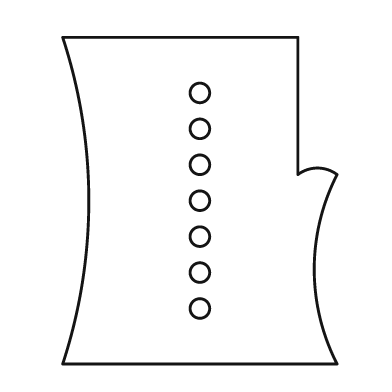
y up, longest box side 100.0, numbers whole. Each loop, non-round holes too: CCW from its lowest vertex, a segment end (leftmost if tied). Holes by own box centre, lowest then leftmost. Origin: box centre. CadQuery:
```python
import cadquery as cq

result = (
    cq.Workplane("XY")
    .moveTo(-42.0, -50.0)
    .lineTo(42.0, -50.0)
    .threePointArc((35.0, -21.0), (42.0, 8.0))
    .threePointArc((36.0, 10.0), (30.0, 8.0))
    .lineTo(30.0, 50.0)
    .lineTo(-42.0, 50.0)
    .threePointArc((-34.0, 0.0), (-42.0, -50.0))
    .close()
    .moveTo(0.0, -33.0)
    .circle(3.0)
    .moveTo(0.0, -22.0)
    .circle(3.0)
    .moveTo(0.0, -11.0)
    .circle(3.0)
    .moveTo(0.0, 0.0)
    .circle(3.0)
    .moveTo(0.0, 11.0)
    .circle(3.0)
    .moveTo(0.0, 22.0)
    .circle(3.0)
    .moveTo(0.0, 33.0)
    .circle(3.0)
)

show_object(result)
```